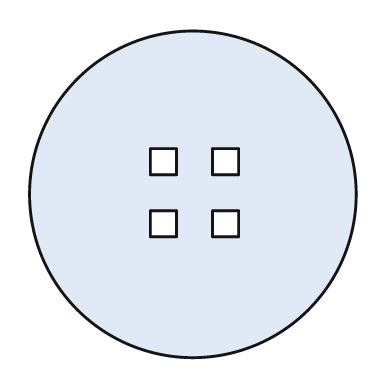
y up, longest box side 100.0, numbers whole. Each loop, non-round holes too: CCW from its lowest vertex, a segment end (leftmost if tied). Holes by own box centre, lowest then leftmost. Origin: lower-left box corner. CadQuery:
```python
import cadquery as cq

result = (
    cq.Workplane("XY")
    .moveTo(50.0, 50.0)
    .circle(50.0)
    .moveTo(37.0, 37.0)
    .lineTo(45.0, 37.0)
    .lineTo(45.0, 45.0)
    .lineTo(37.0, 45.0)
    .close()
    .moveTo(56.0, 37.0)
    .lineTo(64.0, 37.0)
    .lineTo(64.0, 45.0)
    .lineTo(56.0, 45.0)
    .close()
    .moveTo(37.0, 56.0)
    .lineTo(45.0, 56.0)
    .lineTo(45.0, 64.0)
    .lineTo(37.0, 64.0)
    .close()
    .moveTo(56.0, 56.0)
    .lineTo(64.0, 56.0)
    .lineTo(64.0, 64.0)
    .lineTo(56.0, 64.0)
    .close()
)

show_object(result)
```